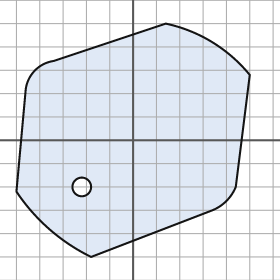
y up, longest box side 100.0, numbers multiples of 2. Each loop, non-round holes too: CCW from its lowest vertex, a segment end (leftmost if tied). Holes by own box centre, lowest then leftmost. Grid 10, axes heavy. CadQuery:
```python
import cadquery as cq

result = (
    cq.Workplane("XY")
    .moveTo(-18.0, -50.0)
    .lineTo(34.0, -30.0)
    .threePointArc((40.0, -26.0), (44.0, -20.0))
    .lineTo(50.0, 28.0)
    .threePointArc((34.0, 42.0), (14.0, 50.0))
    .lineTo(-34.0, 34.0)
    .threePointArc((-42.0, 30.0), (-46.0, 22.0))
    .lineTo(-50.0, -22.0)
    .threePointArc((-36.0, -38.0), (-18.0, -50.0))
    .close()
    .moveTo(-22.0, -20.0)
    .circle(4.0)
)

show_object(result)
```